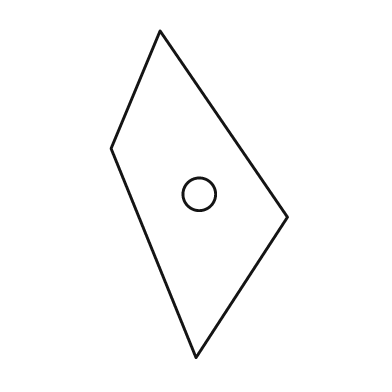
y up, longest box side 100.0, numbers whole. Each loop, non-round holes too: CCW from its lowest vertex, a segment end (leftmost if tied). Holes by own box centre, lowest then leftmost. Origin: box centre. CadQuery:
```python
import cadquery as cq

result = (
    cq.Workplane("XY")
    .moveTo(-1.0, -50.0)
    .lineTo(27.0, -7.0)
    .lineTo(-12.0, 50.0)
    .lineTo(-27.0, 14.0)
    .close()
    .moveTo(0.0, 0.0)
    .circle(5.0)
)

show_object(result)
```